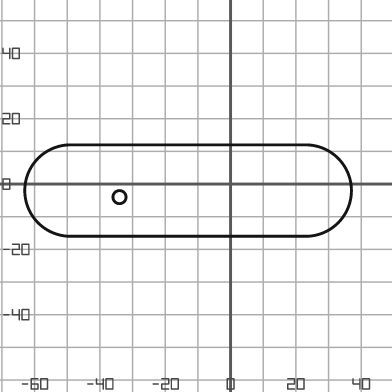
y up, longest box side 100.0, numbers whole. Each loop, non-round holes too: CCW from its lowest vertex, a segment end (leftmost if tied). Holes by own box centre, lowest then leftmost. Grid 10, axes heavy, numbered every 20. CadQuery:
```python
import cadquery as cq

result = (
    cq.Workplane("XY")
    .moveTo(-49.0, -16.0)
    .lineTo(23.0, -16.0)
    .threePointArc((37.0, -2.0), (23.0, 12.0))
    .lineTo(-49.0, 12.0)
    .threePointArc((-63.0, -2.0), (-49.0, -16.0))
    .close()
    .moveTo(-34.0, -4.0)
    .circle(2.0)
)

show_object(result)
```